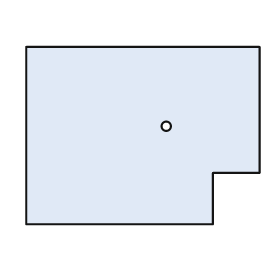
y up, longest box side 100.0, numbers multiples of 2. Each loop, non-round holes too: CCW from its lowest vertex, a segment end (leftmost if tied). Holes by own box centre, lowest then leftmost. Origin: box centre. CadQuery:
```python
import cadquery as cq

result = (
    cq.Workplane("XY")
    .moveTo(-50.0, -38.0)
    .lineTo(30.0, -38.0)
    .lineTo(30.0, -16.0)
    .lineTo(50.0, -16.0)
    .lineTo(50.0, 38.0)
    .lineTo(-50.0, 38.0)
    .close()
    .moveTo(10.0, 4.0)
    .circle(2.0)
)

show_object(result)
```